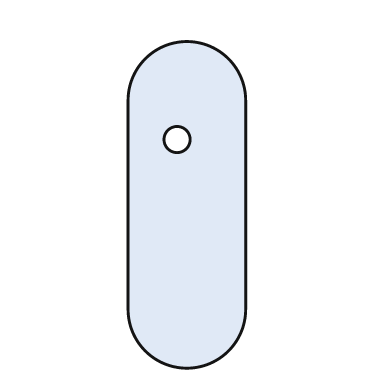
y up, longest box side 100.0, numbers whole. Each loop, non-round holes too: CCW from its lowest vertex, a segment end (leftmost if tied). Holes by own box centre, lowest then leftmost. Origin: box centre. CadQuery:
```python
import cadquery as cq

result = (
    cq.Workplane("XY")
    .moveTo(-18.0, -32.0)
    .threePointArc((0.0, -50.0), (18.0, -32.0))
    .lineTo(18.0, 32.0)
    .threePointArc((0.0, 50.0), (-18.0, 32.0))
    .close()
    .moveTo(-3.0, 20.0)
    .circle(4.0)
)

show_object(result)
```